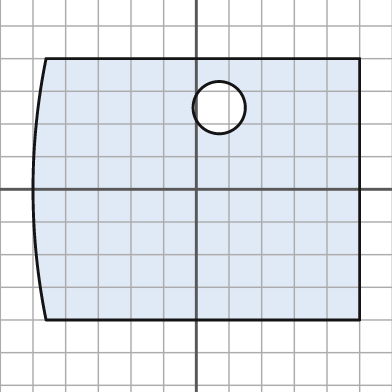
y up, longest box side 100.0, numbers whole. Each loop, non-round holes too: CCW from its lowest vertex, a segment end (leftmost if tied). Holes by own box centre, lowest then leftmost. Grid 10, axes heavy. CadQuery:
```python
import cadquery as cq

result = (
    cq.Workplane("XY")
    .moveTo(-46.0, -40.0)
    .lineTo(50.0, -40.0)
    .lineTo(50.0, 40.0)
    .lineTo(-46.0, 40.0)
    .threePointArc((-50.0, 0.0), (-46.0, -40.0))
    .close()
    .moveTo(7.0, 25.0)
    .circle(8.0)
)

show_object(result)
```